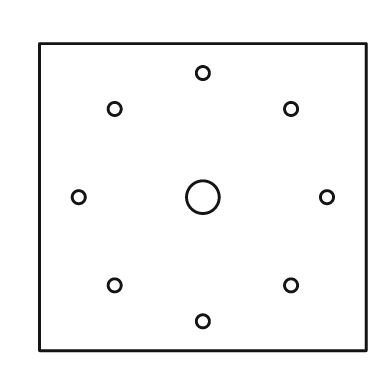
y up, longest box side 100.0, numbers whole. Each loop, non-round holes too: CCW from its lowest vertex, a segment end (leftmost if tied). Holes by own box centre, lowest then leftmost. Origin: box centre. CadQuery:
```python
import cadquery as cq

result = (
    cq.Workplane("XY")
    .moveTo(-50.0, -47.0)
    .lineTo(50.0, -47.0)
    .lineTo(50.0, 47.0)
    .lineTo(-50.0, 47.0)
    .close()
    .moveTo(0.0, -38.0)
    .circle(2.0)
    .moveTo(-27.0, -27.0)
    .circle(2.0)
    .moveTo(27.0, -27.0)
    .circle(2.0)
    .moveTo(-38.0, 0.0)
    .circle(2.0)
    .moveTo(0.0, 0.0)
    .circle(5.0)
    .moveTo(38.0, 0.0)
    .circle(2.0)
    .moveTo(-27.0, 27.0)
    .circle(2.0)
    .moveTo(27.0, 27.0)
    .circle(2.0)
    .moveTo(0.0, 38.0)
    .circle(2.0)
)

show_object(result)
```